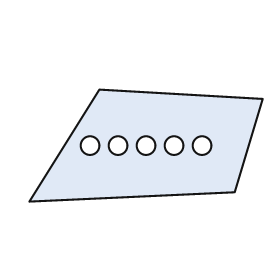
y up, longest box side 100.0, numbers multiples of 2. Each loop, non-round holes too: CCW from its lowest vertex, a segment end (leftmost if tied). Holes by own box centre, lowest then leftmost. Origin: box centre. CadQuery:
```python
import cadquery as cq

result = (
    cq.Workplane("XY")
    .moveTo(-50.0, -24.0)
    .lineTo(38.0, -20.0)
    .lineTo(50.0, 20.0)
    .lineTo(-20.0, 24.0)
    .close()
    .moveTo(-24.0, 0.0)
    .circle(4.0)
    .moveTo(-12.0, 0.0)
    .circle(4.0)
    .moveTo(0.0, 0.0)
    .circle(4.0)
    .moveTo(12.0, 0.0)
    .circle(4.0)
    .moveTo(24.0, 0.0)
    .circle(4.0)
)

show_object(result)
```